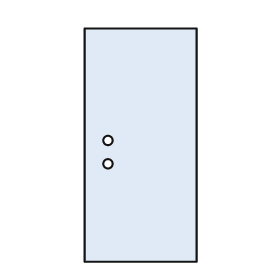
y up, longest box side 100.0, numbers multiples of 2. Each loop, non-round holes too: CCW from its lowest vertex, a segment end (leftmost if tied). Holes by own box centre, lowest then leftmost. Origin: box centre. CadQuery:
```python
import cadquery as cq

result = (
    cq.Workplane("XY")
    .moveTo(-24.0, -50.0)
    .lineTo(24.0, -50.0)
    .lineTo(24.0, 50.0)
    .lineTo(-24.0, 50.0)
    .close()
    .moveTo(-14.0, -8.0)
    .circle(2.0)
    .moveTo(-14.0, 2.0)
    .circle(2.0)
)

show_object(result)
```